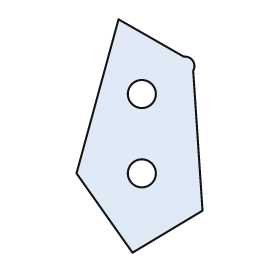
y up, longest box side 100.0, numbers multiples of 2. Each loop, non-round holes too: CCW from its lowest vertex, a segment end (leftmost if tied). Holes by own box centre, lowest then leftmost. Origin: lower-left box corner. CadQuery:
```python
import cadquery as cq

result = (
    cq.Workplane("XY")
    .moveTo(24.0, 0.0)
    .lineTo(54.0, 18.0)
    .lineTo(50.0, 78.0)
    .threePointArc((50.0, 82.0), (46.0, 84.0))
    .lineTo(18.0, 100.0)
    .lineTo(0.0, 34.0)
    .close()
    .moveTo(28.0, 34.0)
    .circle(6.0)
    .moveTo(28.0, 68.0)
    .circle(6.0)
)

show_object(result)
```